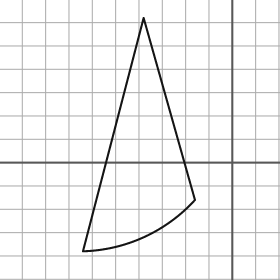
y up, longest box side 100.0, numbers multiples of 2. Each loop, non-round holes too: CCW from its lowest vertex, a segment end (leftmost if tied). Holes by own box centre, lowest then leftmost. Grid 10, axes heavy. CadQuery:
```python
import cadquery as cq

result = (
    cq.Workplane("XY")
    .moveTo(-64.0, -38.0)
    .threePointArc((-38.0, -32.0), (-16.0, -16.0))
    .lineTo(-38.0, 62.0)
    .close()
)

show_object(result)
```